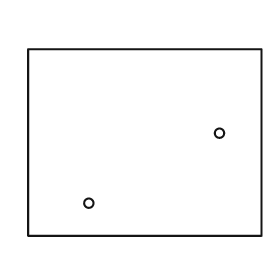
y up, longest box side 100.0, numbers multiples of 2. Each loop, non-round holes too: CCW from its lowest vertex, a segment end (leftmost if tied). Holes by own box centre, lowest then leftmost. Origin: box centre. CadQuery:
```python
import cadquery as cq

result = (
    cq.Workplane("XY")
    .moveTo(-50.0, -40.0)
    .lineTo(50.0, -40.0)
    .lineTo(50.0, 40.0)
    .lineTo(-50.0, 40.0)
    .close()
    .moveTo(-24.0, -26.0)
    .circle(2.0)
    .moveTo(32.0, 4.0)
    .circle(2.0)
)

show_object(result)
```